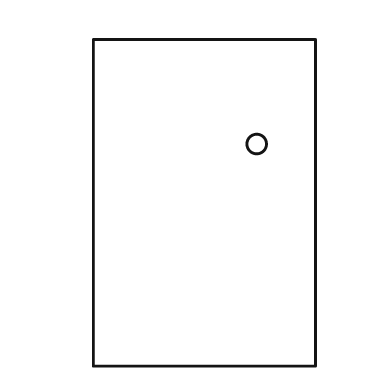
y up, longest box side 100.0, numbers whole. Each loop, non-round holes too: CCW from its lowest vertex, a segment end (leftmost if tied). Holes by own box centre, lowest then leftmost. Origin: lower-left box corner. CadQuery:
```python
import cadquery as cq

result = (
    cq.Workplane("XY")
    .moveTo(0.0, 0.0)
    .lineTo(68.0, 0.0)
    .lineTo(68.0, 100.0)
    .lineTo(0.0, 100.0)
    .close()
    .moveTo(50.0, 68.0)
    .circle(3.0)
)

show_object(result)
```